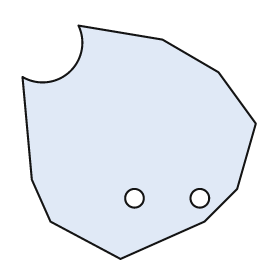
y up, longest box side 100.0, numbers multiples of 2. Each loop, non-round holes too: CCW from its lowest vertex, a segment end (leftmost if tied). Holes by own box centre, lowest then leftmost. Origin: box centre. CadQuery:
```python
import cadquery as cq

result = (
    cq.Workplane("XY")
    .moveTo(-8.0, -50.0)
    .lineTo(28.0, -34.0)
    .lineTo(42.0, -20.0)
    .lineTo(50.0, 8.0)
    .lineTo(34.0, 30.0)
    .lineTo(10.0, 44.0)
    .lineTo(-26.0, 50.0)
    .threePointArc((-30.0, 30.0), (-50.0, 28.0))
    .lineTo(-46.0, -16.0)
    .lineTo(-38.0, -34.0)
    .close()
    .moveTo(-2.0, -24.0)
    .circle(4.0)
    .moveTo(26.0, -24.0)
    .circle(4.0)
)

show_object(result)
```